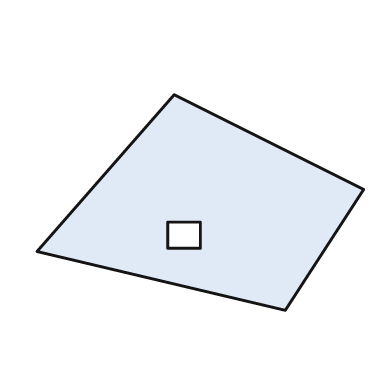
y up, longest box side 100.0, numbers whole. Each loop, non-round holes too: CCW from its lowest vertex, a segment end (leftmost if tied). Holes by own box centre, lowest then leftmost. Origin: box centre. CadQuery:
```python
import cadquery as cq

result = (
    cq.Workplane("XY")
    .moveTo(26.0, -33.0)
    .lineTo(50.0, 4.0)
    .lineTo(-8.0, 33.0)
    .lineTo(-50.0, -15.0)
    .close()
    .moveTo(-10.0, -14.0)
    .lineTo(0.0, -14.0)
    .lineTo(0.0, -6.0)
    .lineTo(-10.0, -6.0)
    .close()
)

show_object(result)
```